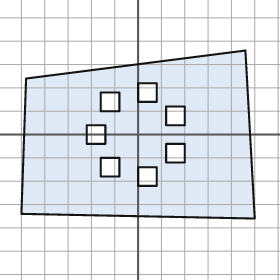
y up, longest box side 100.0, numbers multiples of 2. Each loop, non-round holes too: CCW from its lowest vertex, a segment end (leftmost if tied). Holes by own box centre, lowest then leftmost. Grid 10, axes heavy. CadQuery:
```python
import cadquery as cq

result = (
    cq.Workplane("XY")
    .moveTo(50.0, -36.0)
    .lineTo(46.0, 36.0)
    .lineTo(-48.0, 24.0)
    .lineTo(-50.0, -34.0)
    .close()
    .moveTo(0.0, -22.0)
    .lineTo(8.0, -22.0)
    .lineTo(8.0, -14.0)
    .lineTo(0.0, -14.0)
    .close()
    .moveTo(-16.0, -18.0)
    .lineTo(-8.0, -18.0)
    .lineTo(-8.0, -10.0)
    .lineTo(-16.0, -10.0)
    .close()
    .moveTo(12.0, -12.0)
    .lineTo(20.0, -12.0)
    .lineTo(20.0, -4.0)
    .lineTo(12.0, -4.0)
    .close()
    .moveTo(-22.0, -4.0)
    .lineTo(-14.0, -4.0)
    .lineTo(-14.0, 4.0)
    .lineTo(-22.0, 4.0)
    .close()
    .moveTo(12.0, 4.0)
    .lineTo(20.0, 4.0)
    .lineTo(20.0, 12.0)
    .lineTo(12.0, 12.0)
    .close()
    .moveTo(-16.0, 10.0)
    .lineTo(-8.0, 10.0)
    .lineTo(-8.0, 18.0)
    .lineTo(-16.0, 18.0)
    .close()
    .moveTo(0.0, 14.0)
    .lineTo(8.0, 14.0)
    .lineTo(8.0, 22.0)
    .lineTo(0.0, 22.0)
    .close()
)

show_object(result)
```